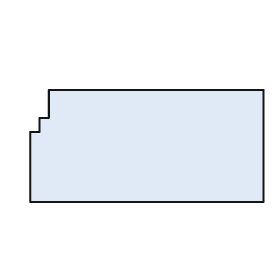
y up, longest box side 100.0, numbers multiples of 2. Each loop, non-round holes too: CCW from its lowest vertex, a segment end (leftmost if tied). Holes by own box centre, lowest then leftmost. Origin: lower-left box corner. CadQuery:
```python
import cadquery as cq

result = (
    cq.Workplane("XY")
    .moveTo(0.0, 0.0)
    .lineTo(100.0, 0.0)
    .lineTo(100.0, 48.0)
    .lineTo(8.0, 48.0)
    .lineTo(8.0, 36.0)
    .lineTo(4.0, 36.0)
    .lineTo(4.0, 30.0)
    .lineTo(0.0, 30.0)
    .close()
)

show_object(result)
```